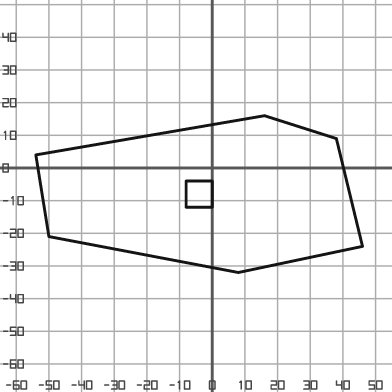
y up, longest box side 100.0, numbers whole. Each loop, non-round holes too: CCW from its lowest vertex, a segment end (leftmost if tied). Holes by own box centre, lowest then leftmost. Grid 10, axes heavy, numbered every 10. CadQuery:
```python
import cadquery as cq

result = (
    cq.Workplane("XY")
    .moveTo(8.0, -32.0)
    .lineTo(46.0, -24.0)
    .lineTo(38.0, 9.0)
    .lineTo(16.0, 16.0)
    .lineTo(-54.0, 4.0)
    .lineTo(-50.0, -21.0)
    .close()
    .moveTo(-8.0, -12.0)
    .lineTo(0.0, -12.0)
    .lineTo(0.0, -4.0)
    .lineTo(-8.0, -4.0)
    .close()
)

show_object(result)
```